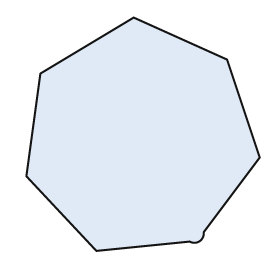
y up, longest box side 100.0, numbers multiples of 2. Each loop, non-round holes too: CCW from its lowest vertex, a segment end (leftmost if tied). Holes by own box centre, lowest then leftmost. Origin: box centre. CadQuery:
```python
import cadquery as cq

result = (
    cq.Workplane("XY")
    .moveTo(-20.0, -50.0)
    .lineTo(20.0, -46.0)
    .threePointArc((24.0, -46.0), (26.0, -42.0))
    .lineTo(50.0, -10.0)
    .lineTo(36.0, 32.0)
    .lineTo(-4.0, 50.0)
    .lineTo(-44.0, 26.0)
    .lineTo(-50.0, -18.0)
    .close()
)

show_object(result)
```